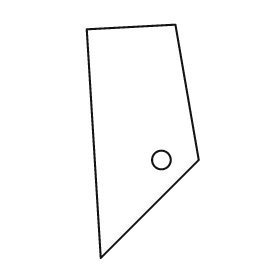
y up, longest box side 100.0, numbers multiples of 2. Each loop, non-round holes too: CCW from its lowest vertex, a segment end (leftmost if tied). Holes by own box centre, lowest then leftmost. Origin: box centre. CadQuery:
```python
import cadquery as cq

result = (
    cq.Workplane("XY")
    .moveTo(-18.0, -50.0)
    .lineTo(24.0, -8.0)
    .lineTo(14.0, 50.0)
    .lineTo(-24.0, 48.0)
    .close()
    .moveTo(8.0, -8.0)
    .circle(4.0)
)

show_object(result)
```